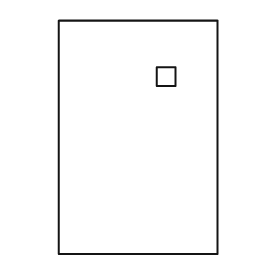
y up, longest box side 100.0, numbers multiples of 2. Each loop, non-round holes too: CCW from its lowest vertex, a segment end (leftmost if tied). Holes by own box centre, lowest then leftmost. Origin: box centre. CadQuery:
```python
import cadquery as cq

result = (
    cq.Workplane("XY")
    .moveTo(-34.0, -50.0)
    .lineTo(34.0, -50.0)
    .lineTo(34.0, 50.0)
    .lineTo(-34.0, 50.0)
    .close()
    .moveTo(8.0, 22.0)
    .lineTo(16.0, 22.0)
    .lineTo(16.0, 30.0)
    .lineTo(8.0, 30.0)
    .close()
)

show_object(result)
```